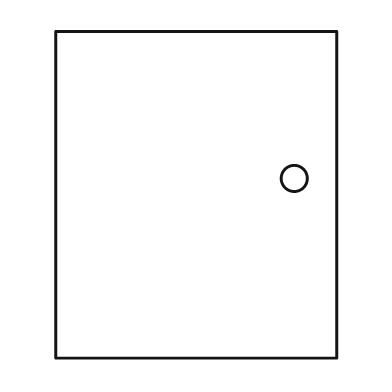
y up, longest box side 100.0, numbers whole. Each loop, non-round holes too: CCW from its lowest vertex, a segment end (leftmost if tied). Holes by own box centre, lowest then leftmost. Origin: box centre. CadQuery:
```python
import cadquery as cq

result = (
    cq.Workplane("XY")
    .moveTo(-43.0, -50.0)
    .lineTo(43.0, -50.0)
    .lineTo(43.0, 50.0)
    .lineTo(-43.0, 50.0)
    .close()
    .moveTo(30.0, 5.0)
    .circle(4.0)
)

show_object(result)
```